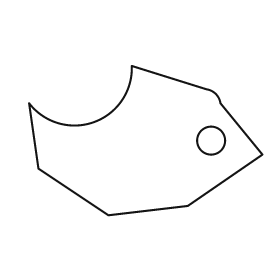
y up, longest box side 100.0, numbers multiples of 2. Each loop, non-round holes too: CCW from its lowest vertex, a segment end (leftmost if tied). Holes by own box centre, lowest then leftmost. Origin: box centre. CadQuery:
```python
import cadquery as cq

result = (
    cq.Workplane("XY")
    .moveTo(-16.0, -32.0)
    .lineTo(18.0, -28.0)
    .lineTo(50.0, -6.0)
    .lineTo(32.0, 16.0)
    .threePointArc((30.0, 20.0), (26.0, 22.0))
    .lineTo(-6.0, 32.0)
    .threePointArc((-22.0, 8.0), (-50.0, 16.0))
    .lineTo(-46.0, -12.0)
    .close()
    .moveTo(28.0, 0.0)
    .circle(6.0)
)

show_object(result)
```